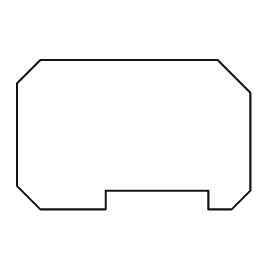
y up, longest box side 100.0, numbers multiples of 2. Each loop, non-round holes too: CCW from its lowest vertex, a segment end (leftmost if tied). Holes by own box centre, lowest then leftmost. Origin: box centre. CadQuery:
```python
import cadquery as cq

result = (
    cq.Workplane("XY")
    .moveTo(-40.0, -32.0)
    .lineTo(-12.0, -32.0)
    .lineTo(-12.0, -24.0)
    .lineTo(32.0, -24.0)
    .lineTo(32.0, -32.0)
    .lineTo(42.0, -32.0)
    .lineTo(50.0, -24.0)
    .lineTo(50.0, 18.0)
    .lineTo(36.0, 32.0)
    .lineTo(-40.0, 32.0)
    .lineTo(-50.0, 22.0)
    .lineTo(-50.0, -22.0)
    .close()
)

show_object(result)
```